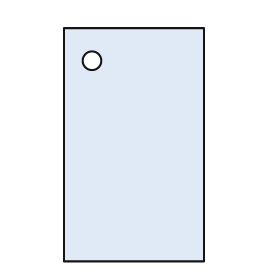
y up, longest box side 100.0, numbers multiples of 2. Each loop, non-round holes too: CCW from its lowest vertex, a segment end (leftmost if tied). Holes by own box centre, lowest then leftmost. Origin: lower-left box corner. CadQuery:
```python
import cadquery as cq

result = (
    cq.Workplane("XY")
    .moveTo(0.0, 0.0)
    .lineTo(60.0, 0.0)
    .lineTo(60.0, 100.0)
    .lineTo(0.0, 100.0)
    .close()
    .moveTo(12.0, 86.0)
    .circle(4.0)
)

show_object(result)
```